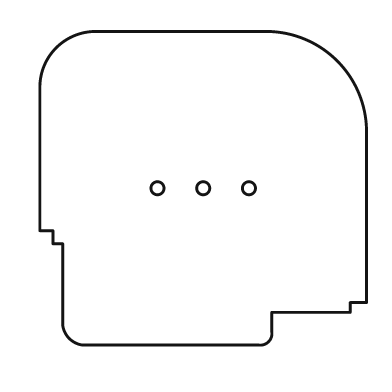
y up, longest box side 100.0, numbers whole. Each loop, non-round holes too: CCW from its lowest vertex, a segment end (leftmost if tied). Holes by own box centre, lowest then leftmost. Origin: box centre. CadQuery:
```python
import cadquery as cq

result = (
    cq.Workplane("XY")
    .moveTo(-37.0, -48.0)
    .lineTo(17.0, -48.0)
    .threePointArc((20.0, -47.0), (21.0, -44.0))
    .lineTo(21.0, -38.0)
    .lineTo(45.0, -38.0)
    .lineTo(45.0, -35.0)
    .lineTo(50.0, -35.0)
    .lineTo(50.0, 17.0)
    .threePointArc((41.0, 39.0), (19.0, 48.0))
    .lineTo(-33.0, 48.0)
    .threePointArc((-45.0, 43.0), (-50.0, 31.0))
    .lineTo(-50.0, -13.0)
    .lineTo(-46.0, -13.0)
    .lineTo(-46.0, -17.0)
    .lineTo(-43.0, -17.0)
    .lineTo(-43.0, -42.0)
    .threePointArc((-41.0, -46.0), (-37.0, -48.0))
    .close()
    .moveTo(-14.0, 0.0)
    .circle(2.0)
    .moveTo(0.0, 0.0)
    .circle(2.0)
    .moveTo(14.0, 0.0)
    .circle(2.0)
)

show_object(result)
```